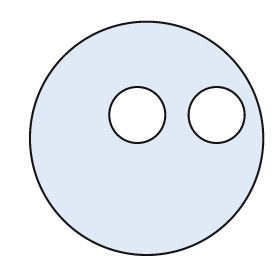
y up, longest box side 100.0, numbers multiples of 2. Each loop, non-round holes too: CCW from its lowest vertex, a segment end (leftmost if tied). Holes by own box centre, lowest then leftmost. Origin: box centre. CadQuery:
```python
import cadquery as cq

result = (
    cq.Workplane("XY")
    .moveTo(0.0, 0.0)
    .circle(50.0)
    .moveTo(-4.0, 10.0)
    .circle(12.0)
    .moveTo(30.0, 10.0)
    .circle(12.0)
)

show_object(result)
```